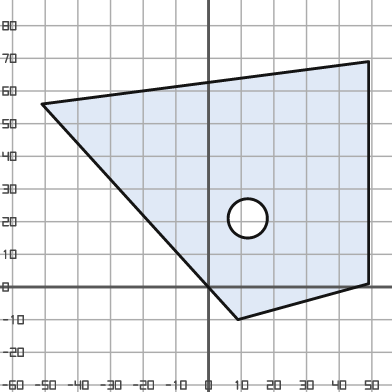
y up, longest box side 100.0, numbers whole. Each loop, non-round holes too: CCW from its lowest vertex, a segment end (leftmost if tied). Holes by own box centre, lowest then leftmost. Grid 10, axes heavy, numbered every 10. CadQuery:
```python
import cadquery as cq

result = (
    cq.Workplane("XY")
    .moveTo(9.0, -10.0)
    .lineTo(49.0, 1.0)
    .lineTo(49.0, 69.0)
    .lineTo(-51.0, 56.0)
    .close()
    .moveTo(12.0, 21.0)
    .circle(6.0)
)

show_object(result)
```